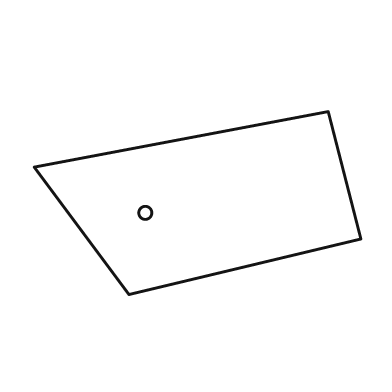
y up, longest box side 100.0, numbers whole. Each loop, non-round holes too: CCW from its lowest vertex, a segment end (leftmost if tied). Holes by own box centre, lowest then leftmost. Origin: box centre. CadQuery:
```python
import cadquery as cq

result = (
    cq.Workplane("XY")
    .moveTo(-21.0, -28.0)
    .lineTo(50.0, -11.0)
    .lineTo(40.0, 28.0)
    .lineTo(-50.0, 11.0)
    .close()
    .moveTo(-16.0, -3.0)
    .circle(2.0)
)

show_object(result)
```